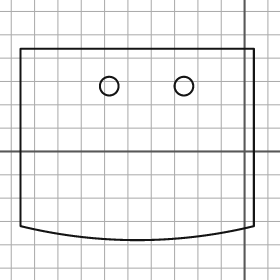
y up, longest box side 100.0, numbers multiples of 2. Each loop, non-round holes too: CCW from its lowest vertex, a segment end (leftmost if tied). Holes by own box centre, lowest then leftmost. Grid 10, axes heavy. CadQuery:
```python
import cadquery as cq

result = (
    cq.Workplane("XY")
    .moveTo(-96.0, -32.0)
    .threePointArc((-46.0, -38.0), (4.0, -32.0))
    .lineTo(4.0, 44.0)
    .lineTo(-96.0, 44.0)
    .close()
    .moveTo(-58.0, 28.0)
    .circle(4.0)
    .moveTo(-26.0, 28.0)
    .circle(4.0)
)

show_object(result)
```